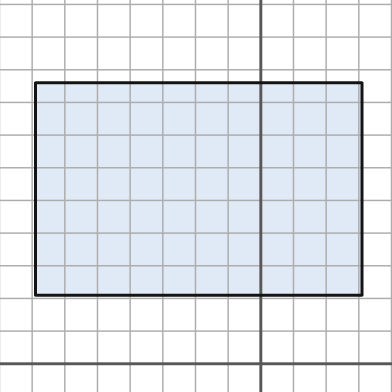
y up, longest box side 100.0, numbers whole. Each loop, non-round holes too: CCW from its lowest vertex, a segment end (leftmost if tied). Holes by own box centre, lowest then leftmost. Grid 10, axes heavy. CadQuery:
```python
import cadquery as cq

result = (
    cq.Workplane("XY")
    .moveTo(-69.0, 21.0)
    .lineTo(31.0, 21.0)
    .lineTo(31.0, 86.0)
    .lineTo(-69.0, 86.0)
    .close()
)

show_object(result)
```